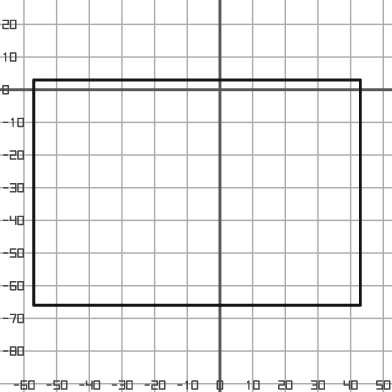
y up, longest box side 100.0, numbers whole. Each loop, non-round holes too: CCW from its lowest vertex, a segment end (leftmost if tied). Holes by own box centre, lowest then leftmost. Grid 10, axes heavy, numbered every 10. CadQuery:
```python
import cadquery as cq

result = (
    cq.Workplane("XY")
    .moveTo(-57.0, -66.0)
    .lineTo(43.0, -66.0)
    .lineTo(43.0, 3.0)
    .lineTo(-57.0, 3.0)
    .close()
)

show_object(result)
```